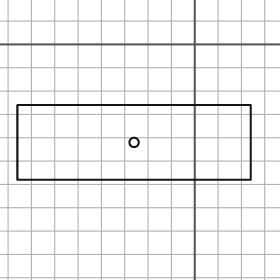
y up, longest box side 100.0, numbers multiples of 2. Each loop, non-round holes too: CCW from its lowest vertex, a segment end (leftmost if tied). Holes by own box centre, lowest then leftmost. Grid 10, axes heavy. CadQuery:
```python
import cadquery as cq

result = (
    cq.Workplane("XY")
    .moveTo(-76.0, -58.0)
    .lineTo(24.0, -58.0)
    .lineTo(24.0, -26.0)
    .lineTo(-76.0, -26.0)
    .close()
    .moveTo(-26.0, -42.0)
    .circle(2.0)
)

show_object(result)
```